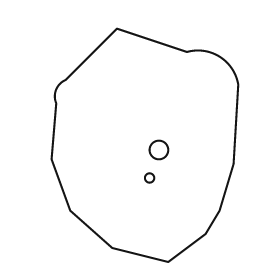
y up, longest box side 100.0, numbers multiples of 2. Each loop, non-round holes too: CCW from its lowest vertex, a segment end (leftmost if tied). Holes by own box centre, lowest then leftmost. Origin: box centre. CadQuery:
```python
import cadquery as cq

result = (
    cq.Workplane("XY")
    .moveTo(10.0, -50.0)
    .lineTo(26.0, -38.0)
    .lineTo(32.0, -28.0)
    .lineTo(38.0, -8.0)
    .lineTo(40.0, 26.0)
    .threePointArc((32.0, 38.0), (18.0, 40.0))
    .lineTo(-12.0, 50.0)
    .lineTo(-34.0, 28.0)
    .threePointArc((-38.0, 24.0), (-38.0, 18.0))
    .lineTo(-40.0, -6.0)
    .lineTo(-32.0, -28.0)
    .lineTo(-14.0, -44.0)
    .close()
    .moveTo(2.0, -14.0)
    .circle(2.0)
    .moveTo(6.0, -2.0)
    .circle(4.0)
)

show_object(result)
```